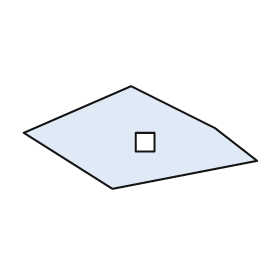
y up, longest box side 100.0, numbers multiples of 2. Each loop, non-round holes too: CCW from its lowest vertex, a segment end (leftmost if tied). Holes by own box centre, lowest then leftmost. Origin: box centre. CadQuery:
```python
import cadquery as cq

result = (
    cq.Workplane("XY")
    .moveTo(-12.0, -22.0)
    .lineTo(50.0, -10.0)
    .lineTo(32.0, 4.0)
    .lineTo(-4.0, 22.0)
    .lineTo(-50.0, 2.0)
    .close()
    .moveTo(-2.0, -6.0)
    .lineTo(6.0, -6.0)
    .lineTo(6.0, 2.0)
    .lineTo(-2.0, 2.0)
    .close()
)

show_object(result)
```